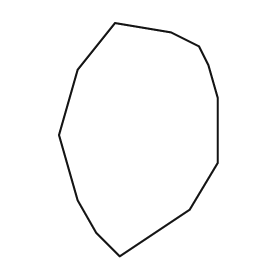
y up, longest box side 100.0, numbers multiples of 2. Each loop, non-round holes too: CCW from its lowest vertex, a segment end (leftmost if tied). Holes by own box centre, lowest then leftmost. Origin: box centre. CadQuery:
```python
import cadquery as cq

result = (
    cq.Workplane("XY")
    .moveTo(-8.0, -50.0)
    .lineTo(22.0, -30.0)
    .lineTo(34.0, -10.0)
    .lineTo(34.0, 18.0)
    .lineTo(30.0, 32.0)
    .lineTo(26.0, 40.0)
    .lineTo(14.0, 46.0)
    .lineTo(-10.0, 50.0)
    .lineTo(-26.0, 30.0)
    .lineTo(-34.0, 2.0)
    .lineTo(-26.0, -26.0)
    .lineTo(-18.0, -40.0)
    .close()
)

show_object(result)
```